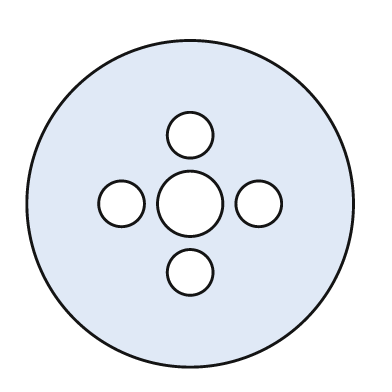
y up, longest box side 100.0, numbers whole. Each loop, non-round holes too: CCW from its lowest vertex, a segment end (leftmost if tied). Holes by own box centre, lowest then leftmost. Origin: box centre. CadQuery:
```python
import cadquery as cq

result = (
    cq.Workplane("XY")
    .moveTo(0.0, 0.0)
    .circle(50.0)
    .moveTo(0.0, -21.0)
    .circle(7.0)
    .moveTo(-21.0, 0.0)
    .circle(7.0)
    .moveTo(0.0, 0.0)
    .circle(10.0)
    .moveTo(21.0, 0.0)
    .circle(7.0)
    .moveTo(0.0, 21.0)
    .circle(7.0)
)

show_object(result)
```